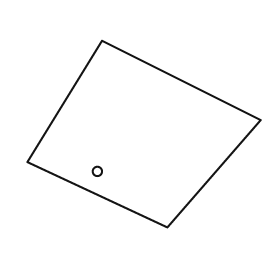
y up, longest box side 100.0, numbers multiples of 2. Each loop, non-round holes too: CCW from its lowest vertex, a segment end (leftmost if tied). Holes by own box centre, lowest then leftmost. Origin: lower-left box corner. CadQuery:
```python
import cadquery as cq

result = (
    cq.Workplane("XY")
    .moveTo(60.0, 0.0)
    .lineTo(100.0, 46.0)
    .lineTo(32.0, 80.0)
    .lineTo(0.0, 28.0)
    .close()
    .moveTo(30.0, 24.0)
    .circle(2.0)
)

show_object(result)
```